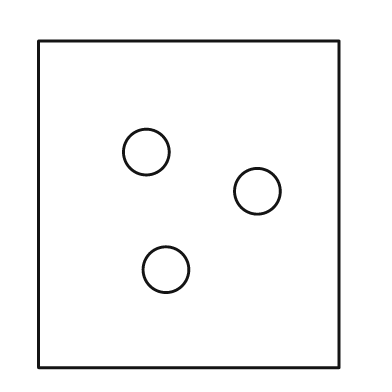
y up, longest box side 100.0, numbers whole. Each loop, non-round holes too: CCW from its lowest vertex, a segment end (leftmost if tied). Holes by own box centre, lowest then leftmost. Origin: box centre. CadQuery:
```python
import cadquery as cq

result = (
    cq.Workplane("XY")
    .moveTo(-46.0, -50.0)
    .lineTo(46.0, -50.0)
    .lineTo(46.0, 50.0)
    .lineTo(-46.0, 50.0)
    .close()
    .moveTo(-7.0, -20.0)
    .circle(7.0)
    .moveTo(21.0, 4.0)
    .circle(7.0)
    .moveTo(-13.0, 16.0)
    .circle(7.0)
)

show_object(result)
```